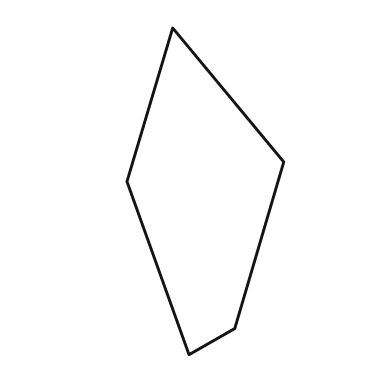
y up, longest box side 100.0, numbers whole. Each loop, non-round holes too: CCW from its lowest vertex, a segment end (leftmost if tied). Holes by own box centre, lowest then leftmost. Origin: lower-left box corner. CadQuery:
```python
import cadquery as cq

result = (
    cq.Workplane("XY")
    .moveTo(19.0, 0.0)
    .lineTo(33.0, 8.0)
    .lineTo(48.0, 59.0)
    .lineTo(14.0, 100.0)
    .lineTo(0.0, 53.0)
    .close()
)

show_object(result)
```